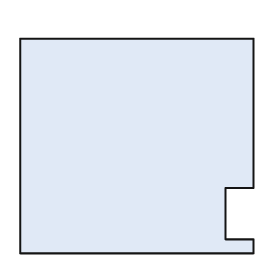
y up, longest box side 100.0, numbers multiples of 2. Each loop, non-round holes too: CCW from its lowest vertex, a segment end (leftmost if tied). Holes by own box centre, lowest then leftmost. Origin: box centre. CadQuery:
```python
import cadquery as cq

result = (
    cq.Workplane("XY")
    .moveTo(-50.0, -46.0)
    .lineTo(50.0, -46.0)
    .lineTo(50.0, -40.0)
    .lineTo(38.0, -40.0)
    .lineTo(38.0, -18.0)
    .lineTo(50.0, -18.0)
    .lineTo(50.0, 46.0)
    .lineTo(-50.0, 46.0)
    .close()
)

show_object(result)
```